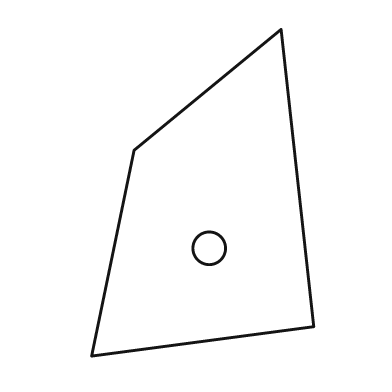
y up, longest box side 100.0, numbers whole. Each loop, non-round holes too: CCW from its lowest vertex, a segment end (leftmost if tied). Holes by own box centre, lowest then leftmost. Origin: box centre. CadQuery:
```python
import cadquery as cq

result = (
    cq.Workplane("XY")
    .moveTo(-34.0, -50.0)
    .lineTo(34.0, -41.0)
    .lineTo(24.0, 50.0)
    .lineTo(-21.0, 13.0)
    .close()
    .moveTo(2.0, -17.0)
    .circle(5.0)
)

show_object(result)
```